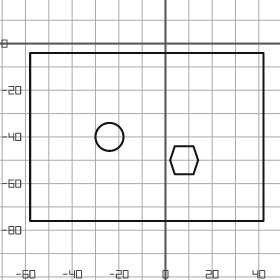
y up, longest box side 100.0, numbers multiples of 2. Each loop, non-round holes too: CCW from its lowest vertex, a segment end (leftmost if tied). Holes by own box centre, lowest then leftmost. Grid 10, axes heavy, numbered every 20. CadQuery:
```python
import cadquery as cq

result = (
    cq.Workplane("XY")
    .moveTo(-58.0, -76.0)
    .lineTo(42.0, -76.0)
    .lineTo(42.0, -4.0)
    .lineTo(-58.0, -4.0)
    .close()
    .moveTo(4.0, -56.0)
    .lineTo(12.0, -56.0)
    .lineTo(14.0, -50.0)
    .lineTo(12.0, -44.0)
    .lineTo(4.0, -44.0)
    .lineTo(2.0, -50.0)
    .close()
    .moveTo(-24.0, -40.0)
    .circle(6.0)
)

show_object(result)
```